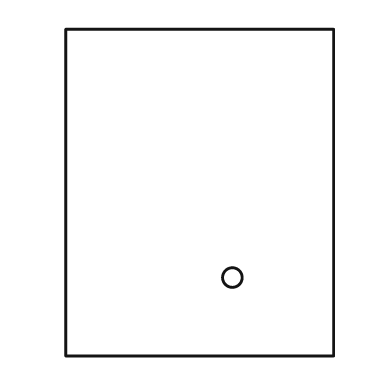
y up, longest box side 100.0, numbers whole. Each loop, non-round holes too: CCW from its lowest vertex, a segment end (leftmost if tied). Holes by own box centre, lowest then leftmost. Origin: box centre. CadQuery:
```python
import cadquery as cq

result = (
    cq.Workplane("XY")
    .moveTo(-41.0, -50.0)
    .lineTo(41.0, -50.0)
    .lineTo(41.0, 50.0)
    .lineTo(-41.0, 50.0)
    .close()
    .moveTo(10.0, -26.0)
    .circle(3.0)
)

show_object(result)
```